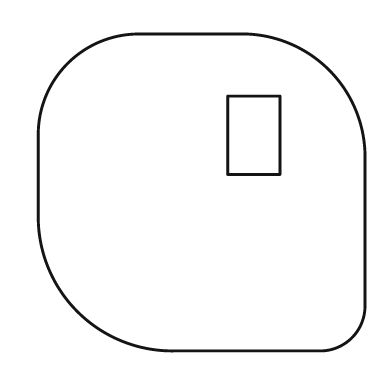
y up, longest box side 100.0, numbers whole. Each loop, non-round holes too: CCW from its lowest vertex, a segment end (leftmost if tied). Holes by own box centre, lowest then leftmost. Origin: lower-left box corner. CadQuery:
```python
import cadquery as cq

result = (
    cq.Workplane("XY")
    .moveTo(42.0, 0.0)
    .lineTo(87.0, 0.0)
    .threePointArc((96.0, 4.0), (100.0, 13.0))
    .lineTo(100.0, 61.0)
    .threePointArc((89.0, 86.0), (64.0, 97.0))
    .lineTo(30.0, 97.0)
    .threePointArc((9.0, 88.0), (0.0, 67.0))
    .lineTo(0.0, 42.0)
    .threePointArc((12.0, 12.0), (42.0, 0.0))
    .close()
    .moveTo(58.0, 54.0)
    .lineTo(74.0, 54.0)
    .lineTo(74.0, 78.0)
    .lineTo(58.0, 78.0)
    .close()
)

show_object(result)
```